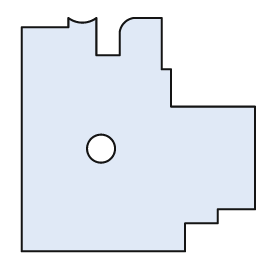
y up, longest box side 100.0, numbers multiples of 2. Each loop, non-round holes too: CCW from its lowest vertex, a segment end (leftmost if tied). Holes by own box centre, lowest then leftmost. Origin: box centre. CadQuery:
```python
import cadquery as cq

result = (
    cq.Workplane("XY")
    .moveTo(-50.0, -50.0)
    .lineTo(20.0, -50.0)
    .lineTo(20.0, -38.0)
    .lineTo(34.0, -38.0)
    .lineTo(34.0, -32.0)
    .lineTo(50.0, -32.0)
    .lineTo(50.0, 12.0)
    .lineTo(14.0, 12.0)
    .lineTo(14.0, 28.0)
    .lineTo(10.0, 28.0)
    .lineTo(10.0, 50.0)
    .lineTo(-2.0, 50.0)
    .threePointArc((-6.0, 48.0), (-8.0, 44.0))
    .lineTo(-8.0, 34.0)
    .lineTo(-18.0, 34.0)
    .lineTo(-18.0, 50.0)
    .threePointArc((-24.0, 48.0), (-30.0, 50.0))
    .lineTo(-30.0, 46.0)
    .lineTo(-50.0, 46.0)
    .close()
    .moveTo(-16.0, -6.0)
    .circle(6.0)
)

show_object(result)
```